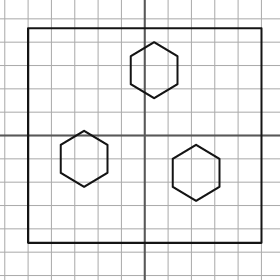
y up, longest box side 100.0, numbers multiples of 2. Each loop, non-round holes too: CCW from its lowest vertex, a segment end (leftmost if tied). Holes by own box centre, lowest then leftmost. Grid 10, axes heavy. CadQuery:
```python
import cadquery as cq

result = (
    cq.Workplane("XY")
    .moveTo(-50.0, -46.0)
    .lineTo(50.0, -46.0)
    .lineTo(50.0, 46.0)
    .lineTo(-50.0, 46.0)
    .close()
    .moveTo(22.0, -28.0)
    .lineTo(32.0, -22.0)
    .lineTo(32.0, -10.0)
    .lineTo(22.0, -4.0)
    .lineTo(12.0, -10.0)
    .lineTo(12.0, -22.0)
    .close()
    .moveTo(-26.0, -22.0)
    .lineTo(-16.0, -16.0)
    .lineTo(-16.0, -4.0)
    .lineTo(-26.0, 2.0)
    .lineTo(-36.0, -4.0)
    .lineTo(-36.0, -16.0)
    .close()
    .moveTo(4.0, 16.0)
    .lineTo(14.0, 22.0)
    .lineTo(14.0, 34.0)
    .lineTo(4.0, 40.0)
    .lineTo(-6.0, 34.0)
    .lineTo(-6.0, 22.0)
    .close()
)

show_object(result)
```